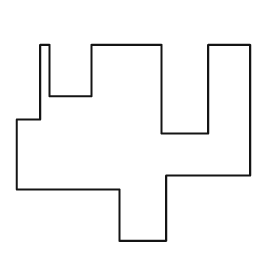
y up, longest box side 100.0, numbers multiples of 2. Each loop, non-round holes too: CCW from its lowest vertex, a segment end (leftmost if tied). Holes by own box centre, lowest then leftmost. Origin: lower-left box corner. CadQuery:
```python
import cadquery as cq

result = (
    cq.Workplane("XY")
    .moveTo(44.0, 0.0)
    .lineTo(64.0, 0.0)
    .lineTo(64.0, 28.0)
    .lineTo(100.0, 28.0)
    .lineTo(100.0, 84.0)
    .lineTo(82.0, 84.0)
    .lineTo(82.0, 46.0)
    .lineTo(62.0, 46.0)
    .lineTo(62.0, 84.0)
    .lineTo(32.0, 84.0)
    .lineTo(32.0, 62.0)
    .lineTo(14.0, 62.0)
    .lineTo(14.0, 84.0)
    .lineTo(10.0, 84.0)
    .lineTo(10.0, 52.0)
    .lineTo(0.0, 52.0)
    .lineTo(0.0, 22.0)
    .lineTo(44.0, 22.0)
    .close()
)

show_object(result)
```